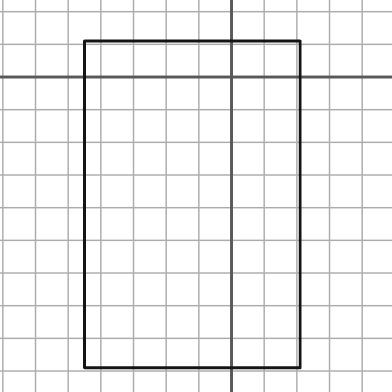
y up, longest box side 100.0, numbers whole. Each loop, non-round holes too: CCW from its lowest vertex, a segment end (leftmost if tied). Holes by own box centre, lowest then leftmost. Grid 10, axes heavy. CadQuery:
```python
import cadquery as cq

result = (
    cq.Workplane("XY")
    .moveTo(-45.0, -89.0)
    .lineTo(21.0, -89.0)
    .lineTo(21.0, 11.0)
    .lineTo(-45.0, 11.0)
    .close()
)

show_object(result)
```